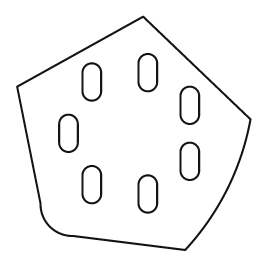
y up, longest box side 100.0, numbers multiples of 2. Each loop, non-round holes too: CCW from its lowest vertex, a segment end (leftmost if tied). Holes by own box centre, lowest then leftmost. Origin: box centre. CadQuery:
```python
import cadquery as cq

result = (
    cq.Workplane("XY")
    .moveTo(22.0, -50.0)
    .threePointArc((40.0, -24.0), (50.0, 6.0))
    .lineTo(4.0, 50.0)
    .lineTo(-50.0, 20.0)
    .lineTo(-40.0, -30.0)
    .threePointArc((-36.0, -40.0), (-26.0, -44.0))
    .close()
    .moveTo(2.0, -30.0)
    .threePointArc((6.0, -34.0), (10.0, -30.0))
    .lineTo(10.0, -22.0)
    .threePointArc((6.0, -18.0), (2.0, -22.0))
    .close()
    .moveTo(-22.0, -26.0)
    .threePointArc((-18.0, -30.0), (-14.0, -26.0))
    .lineTo(-14.0, -18.0)
    .threePointArc((-18.0, -14.0), (-22.0, -18.0))
    .close()
    .moveTo(20.0, -16.0)
    .threePointArc((24.0, -20.0), (28.0, -16.0))
    .lineTo(28.0, -8.0)
    .threePointArc((24.0, -4.0), (20.0, -8.0))
    .close()
    .moveTo(-32.0, -4.0)
    .threePointArc((-28.0, -8.0), (-24.0, -4.0))
    .lineTo(-24.0, 4.0)
    .threePointArc((-28.0, 8.0), (-32.0, 4.0))
    .close()
    .moveTo(20.0, 8.0)
    .threePointArc((24.0, 4.0), (28.0, 8.0))
    .lineTo(28.0, 16.0)
    .threePointArc((24.0, 20.0), (20.0, 16.0))
    .close()
    .moveTo(-22.0, 18.0)
    .threePointArc((-18.0, 14.0), (-14.0, 18.0))
    .lineTo(-14.0, 26.0)
    .threePointArc((-18.0, 30.0), (-22.0, 26.0))
    .close()
    .moveTo(2.0, 22.0)
    .threePointArc((6.0, 18.0), (10.0, 22.0))
    .lineTo(10.0, 30.0)
    .threePointArc((6.0, 34.0), (2.0, 30.0))
    .close()
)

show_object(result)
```